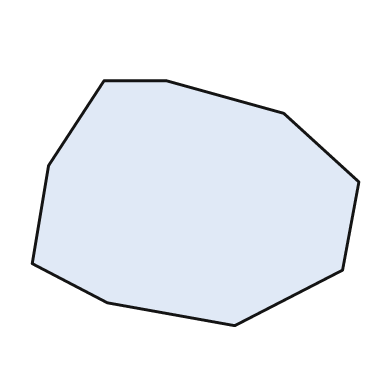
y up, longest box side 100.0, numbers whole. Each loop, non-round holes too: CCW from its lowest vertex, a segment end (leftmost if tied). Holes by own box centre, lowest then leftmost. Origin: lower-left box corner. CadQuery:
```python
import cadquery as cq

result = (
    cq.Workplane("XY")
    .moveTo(62.0, 0.0)
    .lineTo(95.0, 17.0)
    .lineTo(100.0, 44.0)
    .lineTo(77.0, 65.0)
    .lineTo(41.0, 75.0)
    .lineTo(22.0, 75.0)
    .lineTo(5.0, 49.0)
    .lineTo(0.0, 19.0)
    .lineTo(23.0, 7.0)
    .close()
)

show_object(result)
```